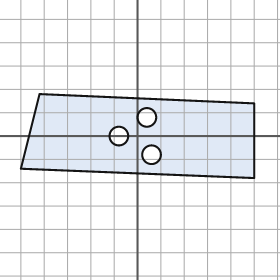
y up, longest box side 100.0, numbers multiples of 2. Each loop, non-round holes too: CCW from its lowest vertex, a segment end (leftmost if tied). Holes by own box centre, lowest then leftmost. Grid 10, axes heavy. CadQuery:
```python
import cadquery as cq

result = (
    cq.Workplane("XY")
    .moveTo(50.0, -18.0)
    .lineTo(50.0, 14.0)
    .lineTo(-42.0, 18.0)
    .lineTo(-50.0, -14.0)
    .close()
    .moveTo(6.0, -8.0)
    .circle(4.0)
    .moveTo(-8.0, 0.0)
    .circle(4.0)
    .moveTo(4.0, 8.0)
    .circle(4.0)
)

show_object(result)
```